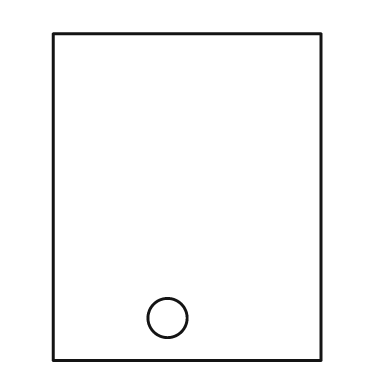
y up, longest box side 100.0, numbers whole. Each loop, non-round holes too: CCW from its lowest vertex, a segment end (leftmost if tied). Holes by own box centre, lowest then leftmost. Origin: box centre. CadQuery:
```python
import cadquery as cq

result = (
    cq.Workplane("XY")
    .moveTo(-41.0, -50.0)
    .lineTo(41.0, -50.0)
    .lineTo(41.0, 50.0)
    .lineTo(-41.0, 50.0)
    .close()
    .moveTo(-6.0, -37.0)
    .circle(6.0)
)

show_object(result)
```